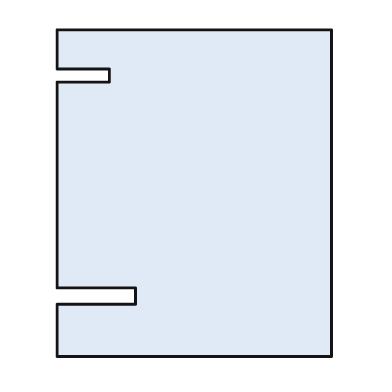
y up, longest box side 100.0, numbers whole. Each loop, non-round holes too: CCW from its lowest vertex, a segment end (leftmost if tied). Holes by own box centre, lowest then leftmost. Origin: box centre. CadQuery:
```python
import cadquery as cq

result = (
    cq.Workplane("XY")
    .moveTo(-42.0, -50.0)
    .lineTo(42.0, -50.0)
    .lineTo(42.0, 50.0)
    .lineTo(-42.0, 50.0)
    .lineTo(-42.0, 38.0)
    .lineTo(-26.0, 38.0)
    .lineTo(-26.0, 34.0)
    .lineTo(-42.0, 34.0)
    .lineTo(-42.0, -29.0)
    .lineTo(-18.0, -29.0)
    .lineTo(-18.0, -34.0)
    .lineTo(-42.0, -34.0)
    .close()
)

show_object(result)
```